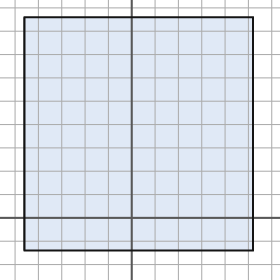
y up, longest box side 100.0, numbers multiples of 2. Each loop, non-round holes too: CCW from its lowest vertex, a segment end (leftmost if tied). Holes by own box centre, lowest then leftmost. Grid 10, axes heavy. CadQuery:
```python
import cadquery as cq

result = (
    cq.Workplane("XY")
    .moveTo(-46.0, -14.0)
    .lineTo(52.0, -14.0)
    .lineTo(52.0, 86.0)
    .lineTo(-46.0, 86.0)
    .close()
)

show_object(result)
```